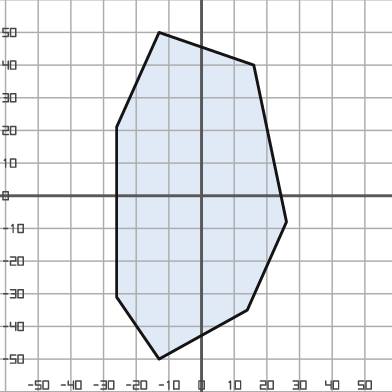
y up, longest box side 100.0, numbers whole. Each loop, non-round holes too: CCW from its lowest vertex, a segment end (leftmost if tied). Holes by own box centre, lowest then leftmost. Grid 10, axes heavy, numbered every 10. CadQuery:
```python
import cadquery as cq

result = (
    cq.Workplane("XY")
    .moveTo(-13.0, -50.0)
    .lineTo(14.0, -35.0)
    .lineTo(26.0, -8.0)
    .lineTo(16.0, 40.0)
    .lineTo(-13.0, 50.0)
    .lineTo(-26.0, 21.0)
    .lineTo(-26.0, -31.0)
    .close()
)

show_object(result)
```